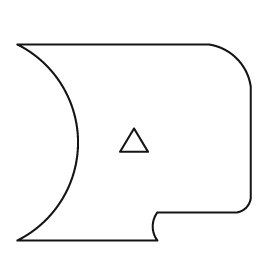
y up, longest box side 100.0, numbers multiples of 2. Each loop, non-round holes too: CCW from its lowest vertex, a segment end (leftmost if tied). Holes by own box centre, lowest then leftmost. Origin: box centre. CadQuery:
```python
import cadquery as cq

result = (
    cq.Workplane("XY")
    .moveTo(-50.0, -42.0)
    .lineTo(10.0, -42.0)
    .threePointArc((8.0, -36.0), (10.0, -30.0))
    .lineTo(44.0, -30.0)
    .threePointArc((48.0, -28.0), (50.0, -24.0))
    .lineTo(50.0, 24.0)
    .threePointArc((44.0, 36.0), (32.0, 42.0))
    .lineTo(-50.0, 42.0)
    .threePointArc((-24.0, 0.0), (-50.0, -42.0))
    .close()
    .moveTo(-6.0, -4.0)
    .lineTo(6.0, -4.0)
    .lineTo(0.0, 6.0)
    .close()
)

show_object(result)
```